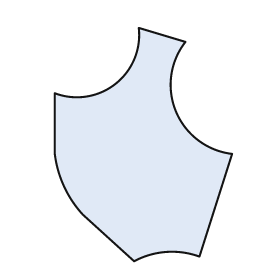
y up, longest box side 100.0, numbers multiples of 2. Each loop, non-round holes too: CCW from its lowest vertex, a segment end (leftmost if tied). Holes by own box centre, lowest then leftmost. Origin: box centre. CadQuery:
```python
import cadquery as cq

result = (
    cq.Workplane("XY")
    .moveTo(-4.0, -50.0)
    .threePointArc((10.0, -46.0), (24.0, -48.0))
    .lineTo(38.0, -4.0)
    .threePointArc((14.0, 14.0), (18.0, 44.0))
    .lineTo(-2.0, 50.0)
    .threePointArc((-12.0, 26.0), (-38.0, 22.0))
    .lineTo(-38.0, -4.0)
    .threePointArc((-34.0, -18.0), (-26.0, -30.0))
    .close()
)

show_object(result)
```